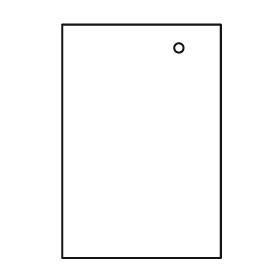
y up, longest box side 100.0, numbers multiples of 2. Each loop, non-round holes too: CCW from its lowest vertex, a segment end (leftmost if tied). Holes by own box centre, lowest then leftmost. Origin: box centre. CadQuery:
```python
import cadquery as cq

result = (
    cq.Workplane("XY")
    .moveTo(-34.0, -50.0)
    .lineTo(34.0, -50.0)
    .lineTo(34.0, 50.0)
    .lineTo(-34.0, 50.0)
    .close()
    .moveTo(16.0, 40.0)
    .circle(2.0)
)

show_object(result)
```